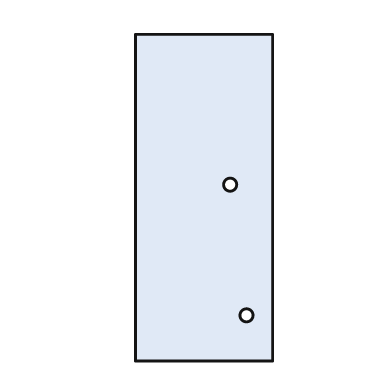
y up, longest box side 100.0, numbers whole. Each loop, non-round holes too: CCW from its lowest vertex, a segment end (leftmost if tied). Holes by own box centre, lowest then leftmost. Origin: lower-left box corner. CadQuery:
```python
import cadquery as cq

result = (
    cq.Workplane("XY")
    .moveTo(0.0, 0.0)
    .lineTo(42.0, 0.0)
    .lineTo(42.0, 100.0)
    .lineTo(0.0, 100.0)
    .close()
    .moveTo(34.0, 14.0)
    .circle(2.0)
    .moveTo(29.0, 54.0)
    .circle(2.0)
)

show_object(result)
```